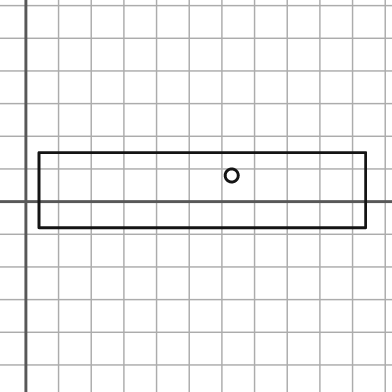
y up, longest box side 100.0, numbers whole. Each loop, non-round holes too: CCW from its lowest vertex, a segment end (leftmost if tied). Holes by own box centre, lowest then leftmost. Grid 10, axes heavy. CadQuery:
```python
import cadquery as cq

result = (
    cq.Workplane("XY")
    .moveTo(4.0, -8.0)
    .lineTo(104.0, -8.0)
    .lineTo(104.0, 15.0)
    .lineTo(4.0, 15.0)
    .close()
    .moveTo(63.0, 8.0)
    .circle(2.0)
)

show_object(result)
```